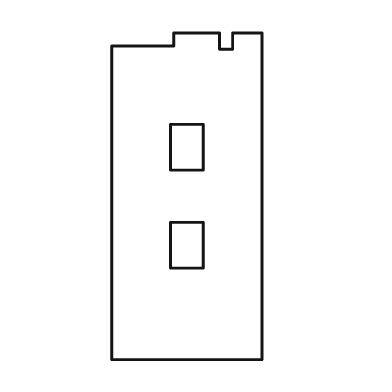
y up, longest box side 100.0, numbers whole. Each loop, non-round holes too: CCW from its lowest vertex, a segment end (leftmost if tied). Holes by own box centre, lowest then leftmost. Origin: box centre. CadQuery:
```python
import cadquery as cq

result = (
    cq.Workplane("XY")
    .moveTo(-23.0, -50.0)
    .lineTo(23.0, -50.0)
    .lineTo(23.0, 50.0)
    .lineTo(14.0, 50.0)
    .lineTo(14.0, 45.0)
    .lineTo(10.0, 45.0)
    .lineTo(10.0, 50.0)
    .lineTo(-4.0, 50.0)
    .lineTo(-4.0, 46.0)
    .lineTo(-23.0, 46.0)
    .close()
    .moveTo(-5.0, -22.0)
    .lineTo(5.0, -22.0)
    .lineTo(5.0, -8.0)
    .lineTo(-5.0, -8.0)
    .close()
    .moveTo(-5.0, 8.0)
    .lineTo(5.0, 8.0)
    .lineTo(5.0, 22.0)
    .lineTo(-5.0, 22.0)
    .close()
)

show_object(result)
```